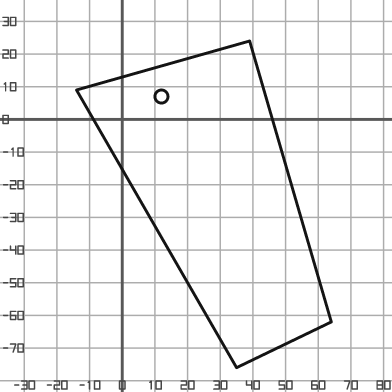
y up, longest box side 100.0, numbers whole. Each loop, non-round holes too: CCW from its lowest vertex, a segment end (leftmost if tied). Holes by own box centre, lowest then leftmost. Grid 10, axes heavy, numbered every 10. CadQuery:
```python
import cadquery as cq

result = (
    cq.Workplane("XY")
    .moveTo(35.0, -76.0)
    .lineTo(64.0, -62.0)
    .lineTo(39.0, 24.0)
    .lineTo(-14.0, 9.0)
    .close()
    .moveTo(12.0, 7.0)
    .circle(2.0)
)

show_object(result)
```